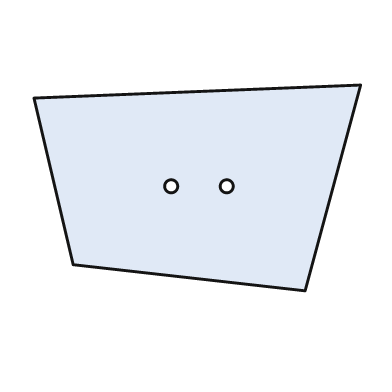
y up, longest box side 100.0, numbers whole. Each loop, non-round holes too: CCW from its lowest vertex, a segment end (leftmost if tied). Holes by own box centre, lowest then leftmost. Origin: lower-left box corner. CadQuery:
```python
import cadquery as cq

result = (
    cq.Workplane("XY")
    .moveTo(83.0, 0.0)
    .lineTo(100.0, 63.0)
    .lineTo(0.0, 59.0)
    .lineTo(12.0, 8.0)
    .close()
    .moveTo(42.0, 32.0)
    .circle(2.0)
    .moveTo(59.0, 32.0)
    .circle(2.0)
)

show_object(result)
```